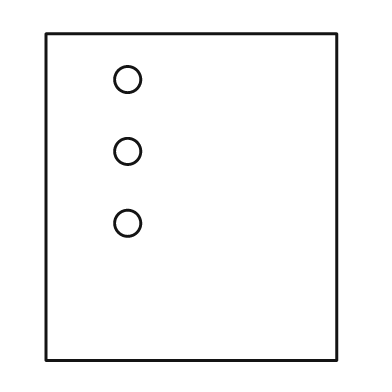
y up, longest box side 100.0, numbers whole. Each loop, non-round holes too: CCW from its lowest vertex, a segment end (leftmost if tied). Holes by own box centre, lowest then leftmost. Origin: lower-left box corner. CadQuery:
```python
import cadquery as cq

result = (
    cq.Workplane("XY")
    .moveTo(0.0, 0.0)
    .lineTo(89.0, 0.0)
    .lineTo(89.0, 100.0)
    .lineTo(0.0, 100.0)
    .close()
    .moveTo(25.0, 42.0)
    .circle(4.0)
    .moveTo(25.0, 64.0)
    .circle(4.0)
    .moveTo(25.0, 86.0)
    .circle(4.0)
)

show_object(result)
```